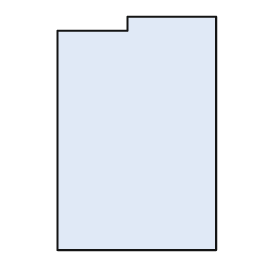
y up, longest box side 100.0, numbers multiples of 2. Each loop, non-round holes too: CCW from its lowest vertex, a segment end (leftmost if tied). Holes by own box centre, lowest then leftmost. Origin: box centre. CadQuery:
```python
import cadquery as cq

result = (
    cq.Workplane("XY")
    .moveTo(-34.0, -50.0)
    .lineTo(34.0, -50.0)
    .lineTo(34.0, 50.0)
    .lineTo(-4.0, 50.0)
    .lineTo(-4.0, 44.0)
    .lineTo(-34.0, 44.0)
    .close()
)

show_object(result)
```